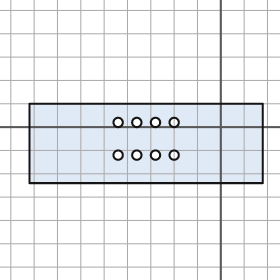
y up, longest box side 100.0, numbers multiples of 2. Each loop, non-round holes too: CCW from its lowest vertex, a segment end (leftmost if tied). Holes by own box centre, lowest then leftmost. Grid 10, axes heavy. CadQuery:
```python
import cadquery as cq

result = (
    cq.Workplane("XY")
    .moveTo(-82.0, -24.0)
    .lineTo(18.0, -24.0)
    .lineTo(18.0, 10.0)
    .lineTo(-82.0, 10.0)
    .close()
    .moveTo(-44.0, -12.0)
    .circle(2.0)
    .moveTo(-36.0, -12.0)
    .circle(2.0)
    .moveTo(-28.0, -12.0)
    .circle(2.0)
    .moveTo(-20.0, -12.0)
    .circle(2.0)
    .moveTo(-44.0, 2.0)
    .circle(2.0)
    .moveTo(-36.0, 2.0)
    .circle(2.0)
    .moveTo(-28.0, 2.0)
    .circle(2.0)
    .moveTo(-20.0, 2.0)
    .circle(2.0)
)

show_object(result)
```